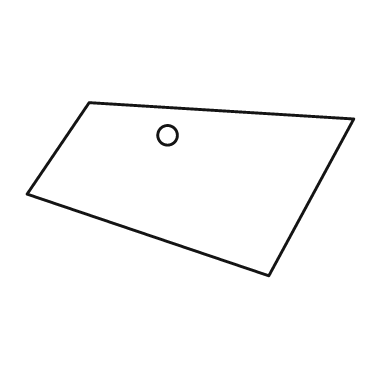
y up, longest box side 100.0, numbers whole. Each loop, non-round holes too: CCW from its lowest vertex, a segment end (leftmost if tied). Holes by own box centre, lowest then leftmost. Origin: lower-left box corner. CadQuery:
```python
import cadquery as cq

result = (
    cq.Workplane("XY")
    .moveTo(74.0, 0.0)
    .lineTo(100.0, 48.0)
    .lineTo(19.0, 53.0)
    .lineTo(0.0, 25.0)
    .close()
    .moveTo(43.0, 43.0)
    .circle(3.0)
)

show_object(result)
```